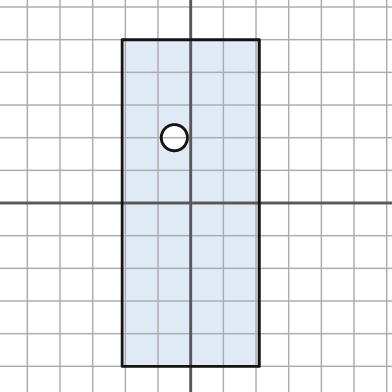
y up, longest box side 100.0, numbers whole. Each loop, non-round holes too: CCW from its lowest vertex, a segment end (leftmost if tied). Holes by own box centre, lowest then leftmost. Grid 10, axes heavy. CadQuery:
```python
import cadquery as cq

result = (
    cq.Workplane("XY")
    .moveTo(-21.0, -50.0)
    .lineTo(21.0, -50.0)
    .lineTo(21.0, 50.0)
    .lineTo(-21.0, 50.0)
    .close()
    .moveTo(-5.0, 20.0)
    .circle(4.0)
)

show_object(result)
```